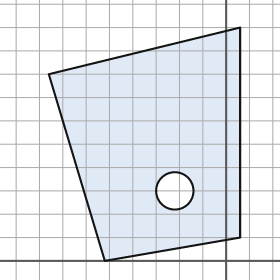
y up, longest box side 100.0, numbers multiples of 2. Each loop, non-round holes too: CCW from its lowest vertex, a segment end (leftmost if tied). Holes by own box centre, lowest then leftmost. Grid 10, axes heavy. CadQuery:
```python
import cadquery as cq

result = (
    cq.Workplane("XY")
    .moveTo(-52.0, 0.0)
    .lineTo(6.0, 10.0)
    .lineTo(6.0, 100.0)
    .lineTo(-76.0, 80.0)
    .close()
    .moveTo(-22.0, 30.0)
    .circle(8.0)
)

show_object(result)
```